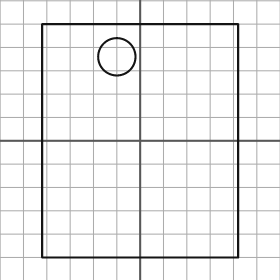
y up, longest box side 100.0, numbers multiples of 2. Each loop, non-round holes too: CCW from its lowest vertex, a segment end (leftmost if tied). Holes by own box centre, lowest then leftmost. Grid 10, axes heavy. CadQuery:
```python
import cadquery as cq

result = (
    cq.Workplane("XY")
    .moveTo(-42.0, -50.0)
    .lineTo(42.0, -50.0)
    .lineTo(42.0, 50.0)
    .lineTo(-42.0, 50.0)
    .close()
    .moveTo(-10.0, 36.0)
    .circle(8.0)
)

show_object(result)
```